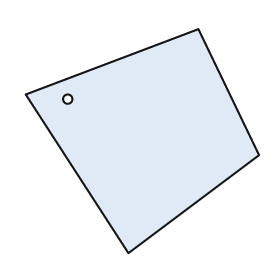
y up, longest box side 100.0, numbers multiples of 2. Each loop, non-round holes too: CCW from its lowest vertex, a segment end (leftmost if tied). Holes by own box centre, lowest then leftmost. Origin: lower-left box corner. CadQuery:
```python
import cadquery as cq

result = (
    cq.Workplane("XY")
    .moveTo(44.0, 0.0)
    .lineTo(100.0, 42.0)
    .lineTo(74.0, 96.0)
    .lineTo(0.0, 68.0)
    .close()
    .moveTo(18.0, 66.0)
    .circle(2.0)
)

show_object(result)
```